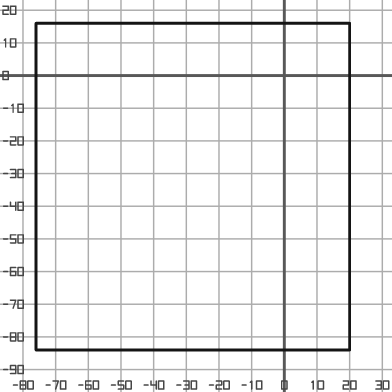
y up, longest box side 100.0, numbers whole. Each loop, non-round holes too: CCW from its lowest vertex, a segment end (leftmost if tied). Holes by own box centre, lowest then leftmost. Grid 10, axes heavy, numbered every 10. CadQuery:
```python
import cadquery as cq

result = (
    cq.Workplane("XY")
    .moveTo(-76.0, -84.0)
    .lineTo(20.0, -84.0)
    .lineTo(20.0, 16.0)
    .lineTo(-76.0, 16.0)
    .close()
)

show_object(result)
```